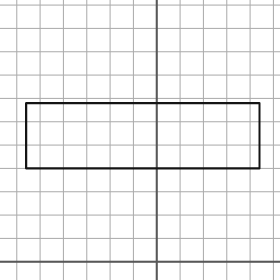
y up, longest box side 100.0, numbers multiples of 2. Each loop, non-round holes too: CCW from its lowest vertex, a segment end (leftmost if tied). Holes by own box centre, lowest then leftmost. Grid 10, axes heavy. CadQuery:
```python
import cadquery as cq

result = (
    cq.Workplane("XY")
    .moveTo(-56.0, 40.0)
    .lineTo(44.0, 40.0)
    .lineTo(44.0, 68.0)
    .lineTo(-56.0, 68.0)
    .close()
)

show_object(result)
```